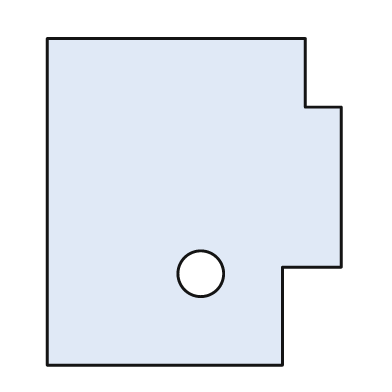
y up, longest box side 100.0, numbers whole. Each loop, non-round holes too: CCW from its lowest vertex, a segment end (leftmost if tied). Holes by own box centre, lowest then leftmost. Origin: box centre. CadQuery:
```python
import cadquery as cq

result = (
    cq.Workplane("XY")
    .moveTo(-45.0, -50.0)
    .lineTo(27.0, -50.0)
    .lineTo(27.0, -20.0)
    .lineTo(45.0, -20.0)
    .lineTo(45.0, 29.0)
    .lineTo(34.0, 29.0)
    .lineTo(34.0, 50.0)
    .lineTo(-45.0, 50.0)
    .close()
    .moveTo(2.0, -22.0)
    .circle(7.0)
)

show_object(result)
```